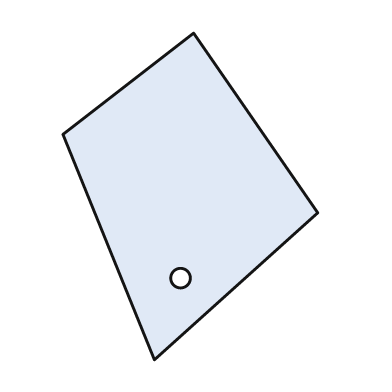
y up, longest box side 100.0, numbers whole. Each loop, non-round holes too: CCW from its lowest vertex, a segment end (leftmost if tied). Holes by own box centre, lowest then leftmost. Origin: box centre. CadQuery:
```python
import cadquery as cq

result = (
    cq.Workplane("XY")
    .moveTo(-11.0, -50.0)
    .lineTo(39.0, -5.0)
    .lineTo(1.0, 50.0)
    .lineTo(-39.0, 19.0)
    .close()
    .moveTo(-3.0, -25.0)
    .circle(3.0)
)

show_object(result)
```